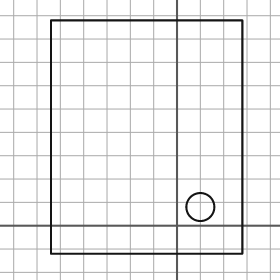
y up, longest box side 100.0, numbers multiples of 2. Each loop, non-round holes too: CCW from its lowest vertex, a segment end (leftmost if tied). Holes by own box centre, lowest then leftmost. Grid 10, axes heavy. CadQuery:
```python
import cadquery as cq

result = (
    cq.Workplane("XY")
    .moveTo(-54.0, -12.0)
    .lineTo(28.0, -12.0)
    .lineTo(28.0, 88.0)
    .lineTo(-54.0, 88.0)
    .close()
    .moveTo(10.0, 8.0)
    .circle(6.0)
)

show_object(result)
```